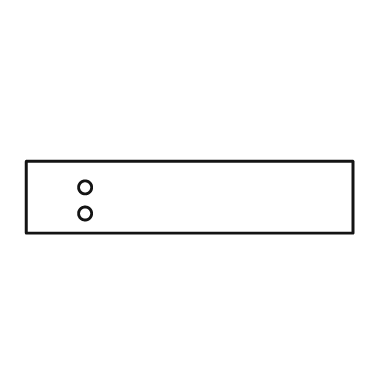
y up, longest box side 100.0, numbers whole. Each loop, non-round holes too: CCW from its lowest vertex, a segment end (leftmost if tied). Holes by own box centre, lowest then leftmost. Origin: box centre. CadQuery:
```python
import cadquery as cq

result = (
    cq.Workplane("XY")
    .moveTo(-50.0, -11.0)
    .lineTo(50.0, -11.0)
    .lineTo(50.0, 11.0)
    .lineTo(-50.0, 11.0)
    .close()
    .moveTo(-32.0, -5.0)
    .circle(2.0)
    .moveTo(-32.0, 3.0)
    .circle(2.0)
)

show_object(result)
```